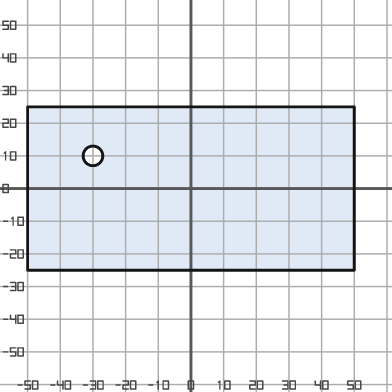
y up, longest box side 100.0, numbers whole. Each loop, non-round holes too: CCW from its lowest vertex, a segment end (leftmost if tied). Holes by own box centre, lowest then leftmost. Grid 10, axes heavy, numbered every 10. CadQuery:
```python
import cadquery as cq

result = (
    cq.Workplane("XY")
    .moveTo(-50.0, -25.0)
    .lineTo(50.0, -25.0)
    .lineTo(50.0, 25.0)
    .lineTo(-50.0, 25.0)
    .close()
    .moveTo(-30.0, 10.0)
    .circle(3.0)
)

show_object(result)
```